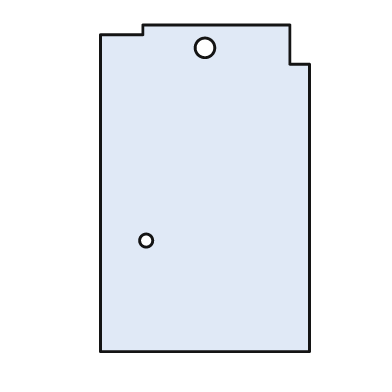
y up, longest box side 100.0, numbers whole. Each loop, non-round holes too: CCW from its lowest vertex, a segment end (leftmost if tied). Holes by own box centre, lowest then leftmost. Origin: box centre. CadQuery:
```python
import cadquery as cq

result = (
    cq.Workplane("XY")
    .moveTo(-32.0, -50.0)
    .lineTo(32.0, -50.0)
    .lineTo(32.0, 38.0)
    .lineTo(26.0, 38.0)
    .lineTo(26.0, 50.0)
    .lineTo(-19.0, 50.0)
    .lineTo(-19.0, 47.0)
    .lineTo(-32.0, 47.0)
    .close()
    .moveTo(-18.0, -16.0)
    .circle(2.0)
    .moveTo(0.0, 43.0)
    .circle(3.0)
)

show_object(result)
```